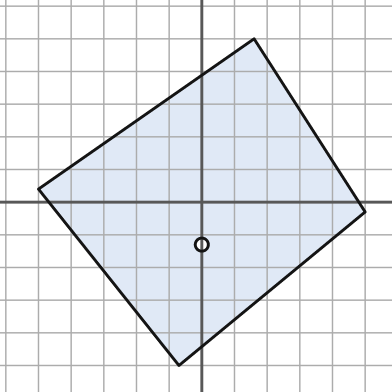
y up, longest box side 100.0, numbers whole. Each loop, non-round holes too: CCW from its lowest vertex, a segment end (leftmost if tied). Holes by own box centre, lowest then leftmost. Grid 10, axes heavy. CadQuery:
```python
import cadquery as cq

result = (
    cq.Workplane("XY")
    .moveTo(-7.0, -50.0)
    .lineTo(50.0, -3.0)
    .lineTo(16.0, 50.0)
    .lineTo(-50.0, 4.0)
    .close()
    .moveTo(0.0, -13.0)
    .circle(2.0)
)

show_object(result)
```